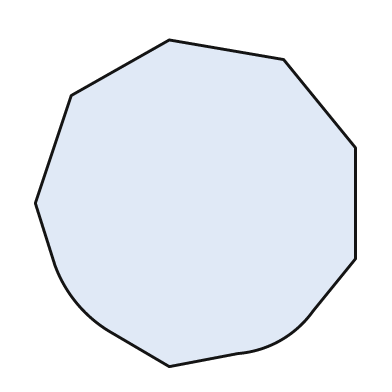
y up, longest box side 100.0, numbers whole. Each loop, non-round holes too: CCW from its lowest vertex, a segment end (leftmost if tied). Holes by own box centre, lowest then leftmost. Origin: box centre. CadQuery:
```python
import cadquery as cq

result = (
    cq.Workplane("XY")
    .moveTo(-8.0, -50.0)
    .lineTo(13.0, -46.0)
    .threePointArc((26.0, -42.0), (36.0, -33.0))
    .lineTo(49.0, -17.0)
    .lineTo(49.0, 17.0)
    .lineTo(27.0, 44.0)
    .lineTo(-8.0, 50.0)
    .lineTo(-38.0, 33.0)
    .lineTo(-49.0, 0.0)
    .lineTo(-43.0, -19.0)
    .threePointArc((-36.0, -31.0), (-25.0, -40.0))
    .close()
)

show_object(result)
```